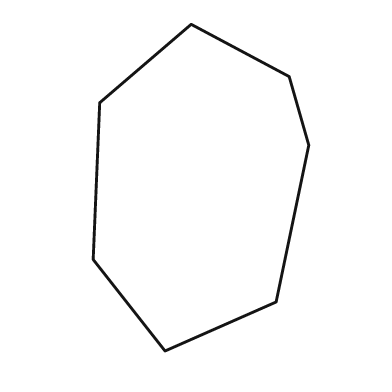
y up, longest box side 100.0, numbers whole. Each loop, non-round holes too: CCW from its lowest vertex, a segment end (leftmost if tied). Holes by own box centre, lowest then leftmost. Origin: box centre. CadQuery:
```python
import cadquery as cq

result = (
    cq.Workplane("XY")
    .moveTo(-11.0, -50.0)
    .lineTo(23.0, -35.0)
    .lineTo(33.0, 13.0)
    .lineTo(27.0, 34.0)
    .lineTo(-3.0, 50.0)
    .lineTo(-31.0, 26.0)
    .lineTo(-33.0, -22.0)
    .close()
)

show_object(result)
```